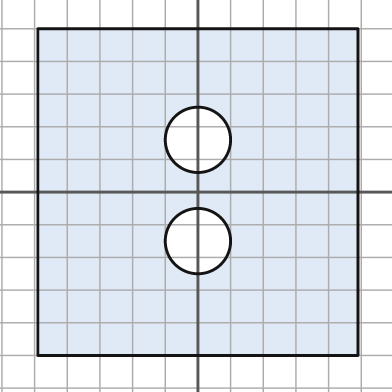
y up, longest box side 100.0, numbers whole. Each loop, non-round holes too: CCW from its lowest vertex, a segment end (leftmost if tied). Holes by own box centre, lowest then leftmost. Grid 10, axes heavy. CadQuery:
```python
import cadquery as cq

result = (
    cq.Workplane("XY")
    .moveTo(-49.0, -50.0)
    .lineTo(49.0, -50.0)
    .lineTo(49.0, 50.0)
    .lineTo(-49.0, 50.0)
    .close()
    .moveTo(0.0, -15.0)
    .circle(10.0)
    .moveTo(0.0, 16.0)
    .circle(10.0)
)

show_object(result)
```